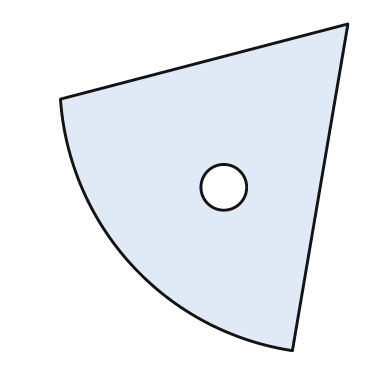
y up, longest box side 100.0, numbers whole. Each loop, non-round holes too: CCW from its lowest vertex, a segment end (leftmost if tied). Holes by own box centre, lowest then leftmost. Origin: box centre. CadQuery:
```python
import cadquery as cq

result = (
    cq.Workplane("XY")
    .moveTo(27.0, -50.0)
    .lineTo(44.0, 50.0)
    .lineTo(-44.0, 27.0)
    .threePointArc((-22.0, -24.0), (27.0, -50.0))
    .close()
    .moveTo(6.0, 0.0)
    .circle(7.0)
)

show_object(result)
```